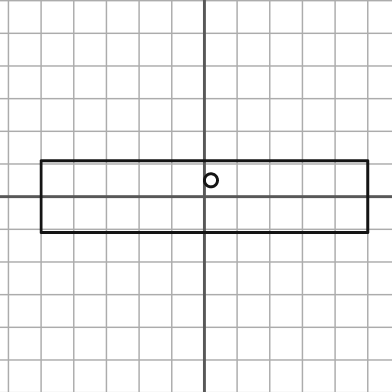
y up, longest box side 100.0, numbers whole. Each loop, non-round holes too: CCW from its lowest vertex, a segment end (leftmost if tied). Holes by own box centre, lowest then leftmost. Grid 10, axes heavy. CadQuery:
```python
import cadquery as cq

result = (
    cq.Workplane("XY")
    .moveTo(-50.0, -11.0)
    .lineTo(50.0, -11.0)
    .lineTo(50.0, 11.0)
    .lineTo(-50.0, 11.0)
    .close()
    .moveTo(2.0, 5.0)
    .circle(2.0)
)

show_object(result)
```